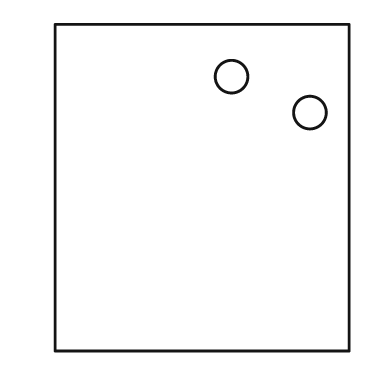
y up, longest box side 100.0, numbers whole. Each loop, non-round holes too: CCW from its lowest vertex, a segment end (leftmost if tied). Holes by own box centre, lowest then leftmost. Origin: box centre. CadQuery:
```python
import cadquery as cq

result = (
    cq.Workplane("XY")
    .moveTo(-45.0, -50.0)
    .lineTo(45.0, -50.0)
    .lineTo(45.0, 50.0)
    .lineTo(-45.0, 50.0)
    .close()
    .moveTo(33.0, 23.0)
    .circle(5.0)
    .moveTo(9.0, 34.0)
    .circle(5.0)
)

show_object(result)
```